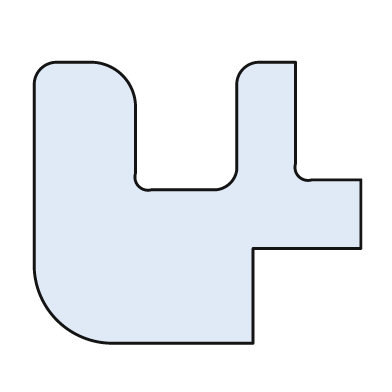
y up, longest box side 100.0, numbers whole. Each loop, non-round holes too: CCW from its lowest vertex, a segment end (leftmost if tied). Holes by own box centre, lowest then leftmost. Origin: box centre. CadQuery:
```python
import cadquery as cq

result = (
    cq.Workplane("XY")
    .moveTo(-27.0, -43.0)
    .lineTo(17.0, -43.0)
    .lineTo(17.0, -14.0)
    .lineTo(50.0, -14.0)
    .lineTo(50.0, 7.0)
    .lineTo(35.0, 7.0)
    .threePointArc((31.0, 8.0), (30.0, 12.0))
    .lineTo(30.0, 43.0)
    .lineTo(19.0, 43.0)
    .threePointArc((14.0, 41.0), (12.0, 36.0))
    .lineTo(12.0, 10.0)
    .threePointArc((10.0, 6.0), (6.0, 4.0))
    .lineTo(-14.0, 4.0)
    .threePointArc((-18.0, 5.0), (-19.0, 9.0))
    .lineTo(-19.0, 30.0)
    .threePointArc((-23.0, 39.0), (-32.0, 43.0))
    .lineTo(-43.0, 43.0)
    .threePointArc((-48.0, 41.0), (-50.0, 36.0))
    .lineTo(-50.0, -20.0)
    .threePointArc((-43.0, -36.0), (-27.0, -43.0))
    .close()
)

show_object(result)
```